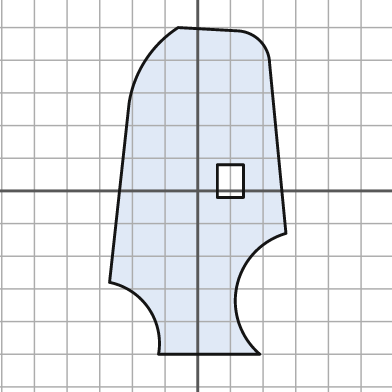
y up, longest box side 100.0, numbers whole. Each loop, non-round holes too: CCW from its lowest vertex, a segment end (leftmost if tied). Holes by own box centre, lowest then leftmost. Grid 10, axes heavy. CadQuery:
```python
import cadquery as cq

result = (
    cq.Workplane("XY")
    .moveTo(-12.0, -50.0)
    .lineTo(19.0, -50.0)
    .threePointArc((12.0, -29.0), (27.0, -13.0))
    .lineTo(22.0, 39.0)
    .threePointArc((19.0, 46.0), (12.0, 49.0))
    .lineTo(-6.0, 50.0)
    .threePointArc((-16.0, 40.0), (-21.0, 27.0))
    .lineTo(-27.0, -28.0)
    .threePointArc((-15.0, -36.0), (-12.0, -50.0))
    .close()
    .moveTo(6.0, -2.0)
    .lineTo(14.0, -2.0)
    .lineTo(14.0, 8.0)
    .lineTo(6.0, 8.0)
    .close()
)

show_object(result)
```